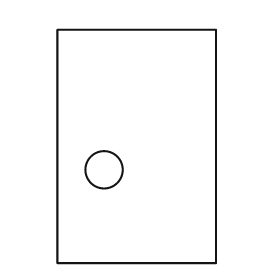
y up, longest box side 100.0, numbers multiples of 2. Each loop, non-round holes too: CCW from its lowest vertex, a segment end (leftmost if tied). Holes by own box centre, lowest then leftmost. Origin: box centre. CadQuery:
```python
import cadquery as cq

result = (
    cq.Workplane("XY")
    .moveTo(-34.0, -50.0)
    .lineTo(34.0, -50.0)
    .lineTo(34.0, 50.0)
    .lineTo(-34.0, 50.0)
    .close()
    .moveTo(-14.0, -10.0)
    .circle(8.0)
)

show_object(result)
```